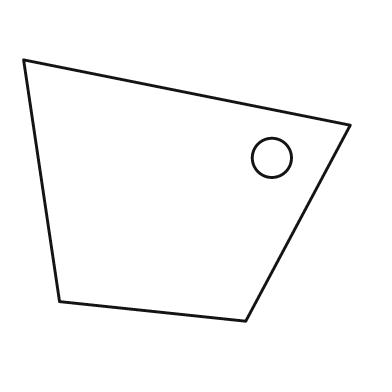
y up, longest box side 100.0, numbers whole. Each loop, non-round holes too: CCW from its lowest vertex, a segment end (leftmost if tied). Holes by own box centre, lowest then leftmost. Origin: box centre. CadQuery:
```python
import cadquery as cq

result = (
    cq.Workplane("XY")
    .moveTo(18.0, -40.0)
    .lineTo(50.0, 20.0)
    .lineTo(-50.0, 40.0)
    .lineTo(-39.0, -34.0)
    .close()
    .moveTo(26.0, 10.0)
    .circle(6.0)
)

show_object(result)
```